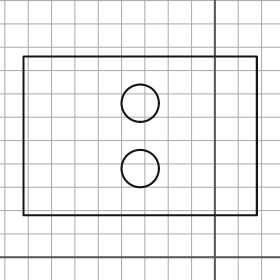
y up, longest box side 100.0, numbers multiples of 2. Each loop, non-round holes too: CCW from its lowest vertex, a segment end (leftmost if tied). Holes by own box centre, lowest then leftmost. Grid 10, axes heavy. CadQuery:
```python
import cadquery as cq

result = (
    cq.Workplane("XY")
    .moveTo(-82.0, 18.0)
    .lineTo(18.0, 18.0)
    .lineTo(18.0, 86.0)
    .lineTo(-82.0, 86.0)
    .close()
    .moveTo(-32.0, 38.0)
    .circle(8.0)
    .moveTo(-32.0, 66.0)
    .circle(8.0)
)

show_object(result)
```